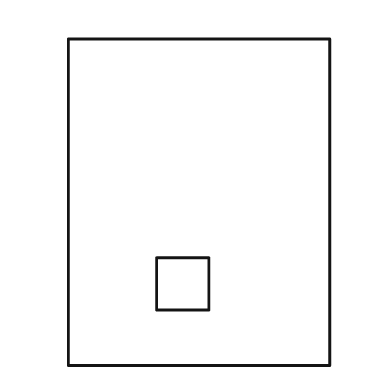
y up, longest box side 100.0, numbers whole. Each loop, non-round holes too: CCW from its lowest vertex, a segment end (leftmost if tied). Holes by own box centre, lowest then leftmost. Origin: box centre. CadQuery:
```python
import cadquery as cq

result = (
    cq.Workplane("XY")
    .moveTo(-40.0, -50.0)
    .lineTo(40.0, -50.0)
    .lineTo(40.0, 50.0)
    .lineTo(-40.0, 50.0)
    .close()
    .moveTo(-13.0, -33.0)
    .lineTo(3.0, -33.0)
    .lineTo(3.0, -17.0)
    .lineTo(-13.0, -17.0)
    .close()
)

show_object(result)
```